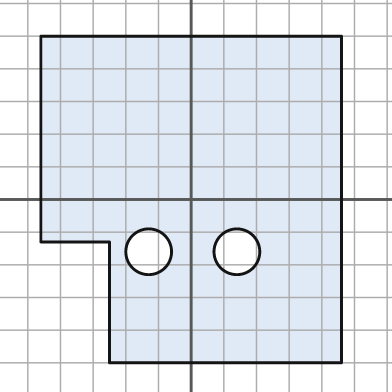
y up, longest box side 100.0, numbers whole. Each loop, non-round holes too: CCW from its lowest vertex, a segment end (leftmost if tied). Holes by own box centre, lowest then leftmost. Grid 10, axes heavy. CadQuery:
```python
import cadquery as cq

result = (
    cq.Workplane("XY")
    .moveTo(-25.0, -50.0)
    .lineTo(46.0, -50.0)
    .lineTo(46.0, 50.0)
    .lineTo(-46.0, 50.0)
    .lineTo(-46.0, -13.0)
    .lineTo(-25.0, -13.0)
    .close()
    .moveTo(-13.0, -16.0)
    .circle(7.0)
    .moveTo(14.0, -16.0)
    .circle(7.0)
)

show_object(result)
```